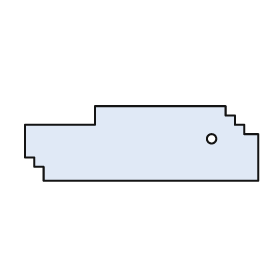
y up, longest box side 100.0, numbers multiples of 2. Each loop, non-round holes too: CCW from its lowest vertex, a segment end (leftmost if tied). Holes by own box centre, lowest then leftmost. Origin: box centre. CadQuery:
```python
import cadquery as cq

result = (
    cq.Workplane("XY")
    .moveTo(-42.0, -16.0)
    .lineTo(50.0, -16.0)
    .lineTo(50.0, 4.0)
    .lineTo(44.0, 4.0)
    .lineTo(44.0, 8.0)
    .lineTo(40.0, 8.0)
    .lineTo(40.0, 12.0)
    .lineTo(36.0, 12.0)
    .lineTo(36.0, 16.0)
    .lineTo(-20.0, 16.0)
    .lineTo(-20.0, 8.0)
    .lineTo(-50.0, 8.0)
    .lineTo(-50.0, -6.0)
    .lineTo(-46.0, -6.0)
    .lineTo(-46.0, -10.0)
    .lineTo(-42.0, -10.0)
    .close()
    .moveTo(30.0, 2.0)
    .circle(2.0)
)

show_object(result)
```